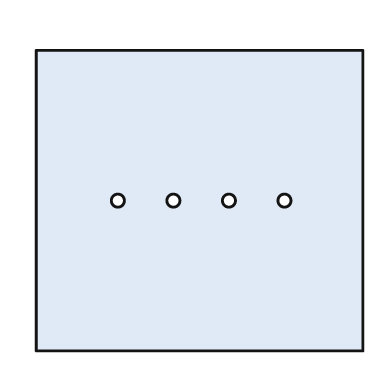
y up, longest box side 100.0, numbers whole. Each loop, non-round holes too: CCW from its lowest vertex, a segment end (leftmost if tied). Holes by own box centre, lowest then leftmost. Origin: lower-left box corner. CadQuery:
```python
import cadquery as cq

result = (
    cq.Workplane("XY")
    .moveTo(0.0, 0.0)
    .lineTo(100.0, 0.0)
    .lineTo(100.0, 92.0)
    .lineTo(0.0, 92.0)
    .close()
    .moveTo(25.0, 46.0)
    .circle(2.0)
    .moveTo(42.0, 46.0)
    .circle(2.0)
    .moveTo(59.0, 46.0)
    .circle(2.0)
    .moveTo(76.0, 46.0)
    .circle(2.0)
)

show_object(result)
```